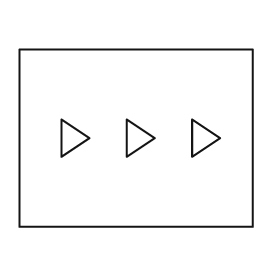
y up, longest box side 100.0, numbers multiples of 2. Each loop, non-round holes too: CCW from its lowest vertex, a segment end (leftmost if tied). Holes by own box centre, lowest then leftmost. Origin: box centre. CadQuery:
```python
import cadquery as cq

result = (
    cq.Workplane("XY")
    .moveTo(-50.0, -38.0)
    .lineTo(50.0, -38.0)
    .lineTo(50.0, 38.0)
    .lineTo(-50.0, 38.0)
    .close()
    .moveTo(-32.0, -8.0)
    .lineTo(-20.0, 0.0)
    .lineTo(-32.0, 8.0)
    .close()
    .moveTo(-4.0, -8.0)
    .lineTo(8.0, 0.0)
    .lineTo(-4.0, 8.0)
    .close()
    .moveTo(24.0, -8.0)
    .lineTo(36.0, 0.0)
    .lineTo(24.0, 8.0)
    .close()
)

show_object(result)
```